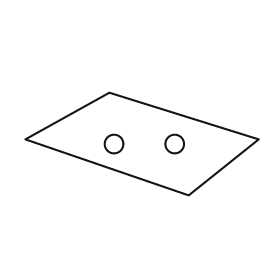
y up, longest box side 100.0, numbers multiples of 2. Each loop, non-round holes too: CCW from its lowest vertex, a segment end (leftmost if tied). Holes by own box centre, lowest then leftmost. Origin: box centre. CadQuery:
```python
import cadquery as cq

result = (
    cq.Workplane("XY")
    .moveTo(20.0, -22.0)
    .lineTo(50.0, 2.0)
    .lineTo(-14.0, 22.0)
    .lineTo(-50.0, 2.0)
    .close()
    .moveTo(-12.0, 0.0)
    .circle(4.0)
    .moveTo(14.0, 0.0)
    .circle(4.0)
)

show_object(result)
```